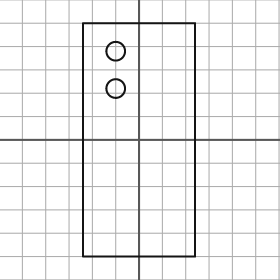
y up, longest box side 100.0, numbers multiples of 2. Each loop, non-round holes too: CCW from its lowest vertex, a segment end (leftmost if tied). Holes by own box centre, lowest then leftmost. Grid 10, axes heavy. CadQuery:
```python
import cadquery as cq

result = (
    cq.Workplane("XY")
    .moveTo(-24.0, -50.0)
    .lineTo(24.0, -50.0)
    .lineTo(24.0, 50.0)
    .lineTo(-24.0, 50.0)
    .close()
    .moveTo(-10.0, 22.0)
    .circle(4.0)
    .moveTo(-10.0, 38.0)
    .circle(4.0)
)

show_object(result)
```